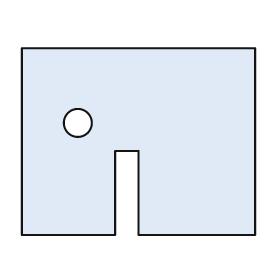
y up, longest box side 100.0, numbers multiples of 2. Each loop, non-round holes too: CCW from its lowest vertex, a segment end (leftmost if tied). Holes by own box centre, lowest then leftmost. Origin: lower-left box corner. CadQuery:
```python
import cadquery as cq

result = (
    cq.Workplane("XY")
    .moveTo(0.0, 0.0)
    .lineTo(40.0, 0.0)
    .lineTo(40.0, 36.0)
    .lineTo(50.0, 36.0)
    .lineTo(50.0, 0.0)
    .lineTo(100.0, 0.0)
    .lineTo(100.0, 80.0)
    .lineTo(0.0, 80.0)
    .close()
    .moveTo(24.0, 48.0)
    .circle(6.0)
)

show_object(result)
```